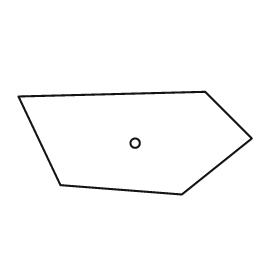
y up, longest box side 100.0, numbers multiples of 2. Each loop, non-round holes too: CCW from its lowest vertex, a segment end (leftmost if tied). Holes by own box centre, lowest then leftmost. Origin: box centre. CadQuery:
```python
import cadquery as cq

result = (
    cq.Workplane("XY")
    .moveTo(20.0, -22.0)
    .lineTo(50.0, 2.0)
    .lineTo(30.0, 22.0)
    .lineTo(-50.0, 20.0)
    .lineTo(-32.0, -18.0)
    .close()
    .moveTo(0.0, 0.0)
    .circle(2.0)
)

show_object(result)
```